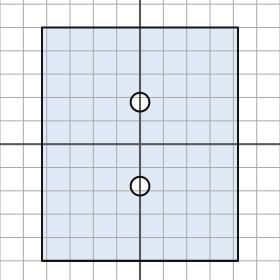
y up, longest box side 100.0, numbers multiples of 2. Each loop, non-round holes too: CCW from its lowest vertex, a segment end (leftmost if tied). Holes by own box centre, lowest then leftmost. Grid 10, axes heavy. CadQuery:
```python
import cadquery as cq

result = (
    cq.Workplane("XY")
    .moveTo(-42.0, -50.0)
    .lineTo(42.0, -50.0)
    .lineTo(42.0, 50.0)
    .lineTo(-42.0, 50.0)
    .close()
    .moveTo(0.0, -18.0)
    .circle(4.0)
    .moveTo(0.0, 18.0)
    .circle(4.0)
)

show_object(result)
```